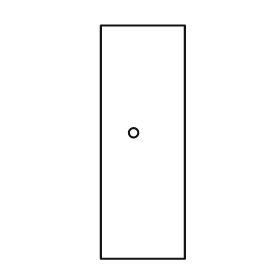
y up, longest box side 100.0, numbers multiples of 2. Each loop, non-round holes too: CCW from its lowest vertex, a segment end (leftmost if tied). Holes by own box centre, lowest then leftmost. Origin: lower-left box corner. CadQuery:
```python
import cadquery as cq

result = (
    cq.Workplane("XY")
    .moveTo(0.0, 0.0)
    .lineTo(36.0, 0.0)
    .lineTo(36.0, 100.0)
    .lineTo(0.0, 100.0)
    .close()
    .moveTo(14.0, 54.0)
    .circle(2.0)
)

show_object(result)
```